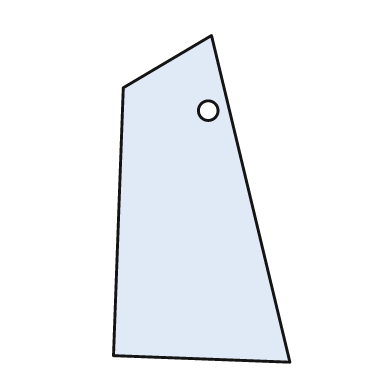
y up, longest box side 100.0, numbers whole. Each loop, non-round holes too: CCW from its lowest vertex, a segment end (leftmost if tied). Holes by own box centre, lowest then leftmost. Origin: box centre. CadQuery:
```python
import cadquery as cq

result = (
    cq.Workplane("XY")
    .moveTo(27.0, -50.0)
    .lineTo(3.0, 50.0)
    .lineTo(-24.0, 34.0)
    .lineTo(-27.0, -48.0)
    .close()
    .moveTo(2.0, 27.0)
    .circle(3.0)
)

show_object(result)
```